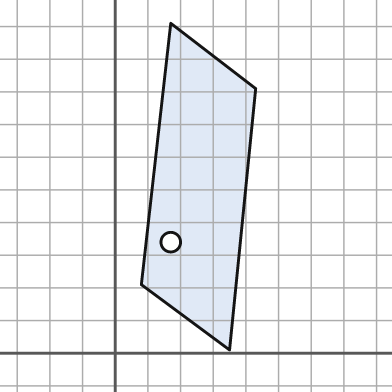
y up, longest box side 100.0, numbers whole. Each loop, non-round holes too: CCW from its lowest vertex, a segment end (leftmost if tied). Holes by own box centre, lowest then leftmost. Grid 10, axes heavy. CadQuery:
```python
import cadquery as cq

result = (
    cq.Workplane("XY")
    .moveTo(35.0, 1.0)
    .lineTo(43.0, 81.0)
    .lineTo(17.0, 101.0)
    .lineTo(8.0, 21.0)
    .close()
    .moveTo(17.0, 34.0)
    .circle(3.0)
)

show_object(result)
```